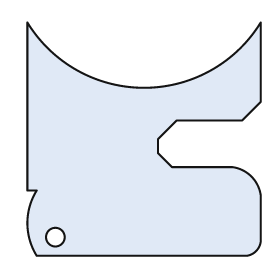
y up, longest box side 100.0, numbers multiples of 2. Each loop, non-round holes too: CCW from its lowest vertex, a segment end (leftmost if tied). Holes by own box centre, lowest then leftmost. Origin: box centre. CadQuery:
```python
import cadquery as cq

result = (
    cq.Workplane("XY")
    .moveTo(-46.0, -50.0)
    .lineTo(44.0, -50.0)
    .threePointArc((48.0, -48.0), (50.0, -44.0))
    .lineTo(50.0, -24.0)
    .threePointArc((46.0, -16.0), (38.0, -12.0))
    .lineTo(12.0, -12.0)
    .lineTo(6.0, -6.0)
    .lineTo(6.0, 0.0)
    .lineTo(14.0, 8.0)
    .lineTo(42.0, 8.0)
    .lineTo(50.0, 16.0)
    .lineTo(50.0, 50.0)
    .threePointArc((0.0, 22.0), (-50.0, 50.0))
    .lineTo(-50.0, -22.0)
    .lineTo(-46.0, -22.0)
    .threePointArc((-50.0, -36.0), (-46.0, -50.0))
    .close()
    .moveTo(-38.0, -42.0)
    .circle(4.0)
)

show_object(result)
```